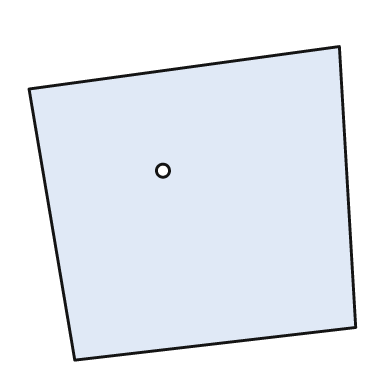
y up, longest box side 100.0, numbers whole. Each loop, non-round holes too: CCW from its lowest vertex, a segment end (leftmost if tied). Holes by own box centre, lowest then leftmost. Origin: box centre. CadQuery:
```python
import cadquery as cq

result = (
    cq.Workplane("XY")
    .moveTo(-36.0, -48.0)
    .lineTo(50.0, -38.0)
    .lineTo(45.0, 48.0)
    .lineTo(-50.0, 35.0)
    .close()
    .moveTo(-9.0, 10.0)
    .circle(2.0)
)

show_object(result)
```